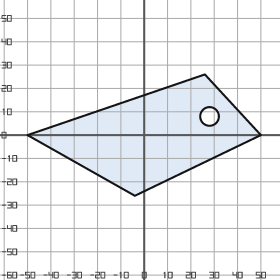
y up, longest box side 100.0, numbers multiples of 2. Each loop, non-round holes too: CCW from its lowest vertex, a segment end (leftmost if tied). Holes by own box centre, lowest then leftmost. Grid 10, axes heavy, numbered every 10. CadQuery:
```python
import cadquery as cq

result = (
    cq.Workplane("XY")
    .moveTo(-4.0, -26.0)
    .lineTo(50.0, 0.0)
    .lineTo(26.0, 26.0)
    .lineTo(-50.0, 0.0)
    .close()
    .moveTo(28.0, 8.0)
    .circle(4.0)
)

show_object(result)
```